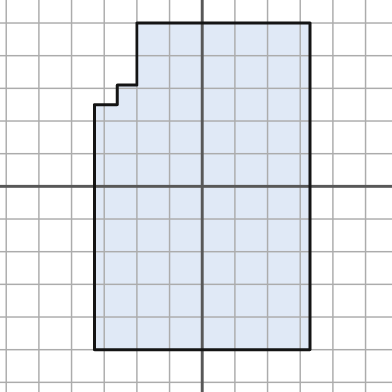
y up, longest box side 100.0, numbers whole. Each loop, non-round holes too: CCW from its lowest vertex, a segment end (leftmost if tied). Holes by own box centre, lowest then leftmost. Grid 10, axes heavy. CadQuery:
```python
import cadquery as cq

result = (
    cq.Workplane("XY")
    .moveTo(-33.0, -50.0)
    .lineTo(33.0, -50.0)
    .lineTo(33.0, 50.0)
    .lineTo(-20.0, 50.0)
    .lineTo(-20.0, 31.0)
    .lineTo(-26.0, 31.0)
    .lineTo(-26.0, 25.0)
    .lineTo(-33.0, 25.0)
    .close()
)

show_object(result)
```